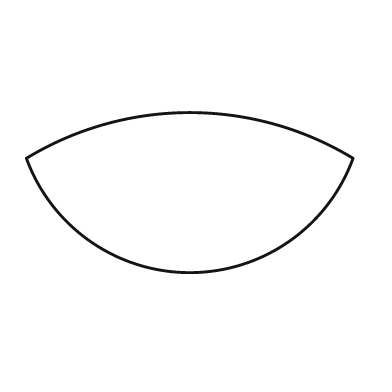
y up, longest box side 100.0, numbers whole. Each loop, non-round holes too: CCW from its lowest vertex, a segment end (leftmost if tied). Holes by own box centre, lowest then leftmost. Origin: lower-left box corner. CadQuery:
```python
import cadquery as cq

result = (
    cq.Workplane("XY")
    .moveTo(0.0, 35.0)
    .threePointArc((50.0, 0.0), (100.0, 35.0))
    .threePointArc((50.0, 49.0), (0.0, 35.0))
    .close()
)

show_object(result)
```